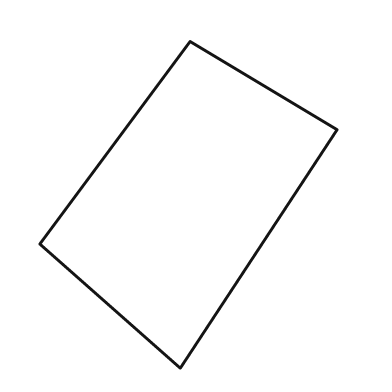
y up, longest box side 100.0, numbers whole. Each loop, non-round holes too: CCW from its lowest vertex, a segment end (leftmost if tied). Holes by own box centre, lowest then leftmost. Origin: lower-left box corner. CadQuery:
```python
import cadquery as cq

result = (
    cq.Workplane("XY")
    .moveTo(43.0, 0.0)
    .lineTo(91.0, 73.0)
    .lineTo(46.0, 100.0)
    .lineTo(0.0, 38.0)
    .close()
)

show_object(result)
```